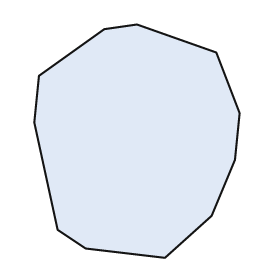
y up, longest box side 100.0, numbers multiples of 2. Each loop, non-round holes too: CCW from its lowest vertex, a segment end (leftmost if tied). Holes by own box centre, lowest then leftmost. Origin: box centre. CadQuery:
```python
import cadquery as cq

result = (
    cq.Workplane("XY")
    .moveTo(12.0, -50.0)
    .lineTo(32.0, -32.0)
    .lineTo(42.0, -8.0)
    .lineTo(44.0, 12.0)
    .lineTo(34.0, 38.0)
    .lineTo(0.0, 50.0)
    .lineTo(-14.0, 48.0)
    .lineTo(-42.0, 28.0)
    .lineTo(-44.0, 8.0)
    .lineTo(-34.0, -38.0)
    .lineTo(-22.0, -46.0)
    .close()
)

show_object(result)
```